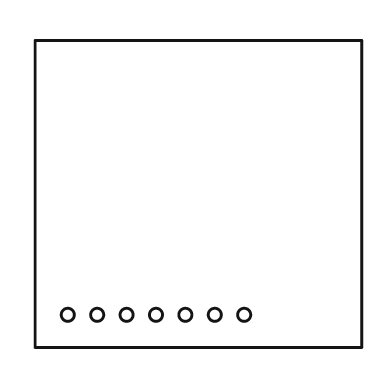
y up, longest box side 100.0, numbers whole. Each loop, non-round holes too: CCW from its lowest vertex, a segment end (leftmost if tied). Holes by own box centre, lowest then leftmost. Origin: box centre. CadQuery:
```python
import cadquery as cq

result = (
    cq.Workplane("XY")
    .moveTo(-50.0, -47.0)
    .lineTo(50.0, -47.0)
    .lineTo(50.0, 47.0)
    .lineTo(-50.0, 47.0)
    .close()
    .moveTo(-40.0, -37.0)
    .circle(2.0)
    .moveTo(-31.0, -37.0)
    .circle(2.0)
    .moveTo(-22.0, -37.0)
    .circle(2.0)
    .moveTo(-13.0, -37.0)
    .circle(2.0)
    .moveTo(-4.0, -37.0)
    .circle(2.0)
    .moveTo(5.0, -37.0)
    .circle(2.0)
    .moveTo(14.0, -37.0)
    .circle(2.0)
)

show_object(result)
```